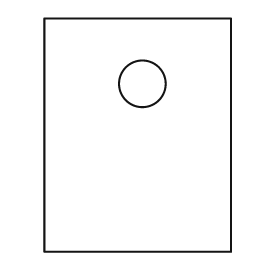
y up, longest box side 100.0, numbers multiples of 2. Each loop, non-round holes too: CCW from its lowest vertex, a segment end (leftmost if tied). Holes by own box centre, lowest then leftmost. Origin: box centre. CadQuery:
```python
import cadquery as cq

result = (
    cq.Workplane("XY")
    .moveTo(-40.0, -50.0)
    .lineTo(40.0, -50.0)
    .lineTo(40.0, 50.0)
    .lineTo(-40.0, 50.0)
    .close()
    .moveTo(2.0, 22.0)
    .circle(10.0)
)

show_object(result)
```